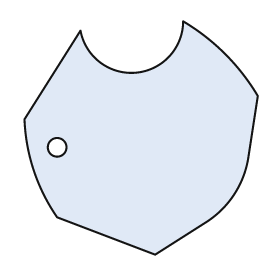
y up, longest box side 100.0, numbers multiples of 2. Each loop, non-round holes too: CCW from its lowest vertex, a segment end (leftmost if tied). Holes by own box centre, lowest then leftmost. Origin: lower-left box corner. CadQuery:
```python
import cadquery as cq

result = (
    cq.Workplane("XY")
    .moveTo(56.0, 0.0)
    .lineTo(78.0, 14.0)
    .threePointArc((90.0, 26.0), (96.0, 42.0))
    .lineTo(100.0, 68.0)
    .threePointArc((86.0, 86.0), (68.0, 100.0))
    .threePointArc((48.0, 78.0), (24.0, 96.0))
    .lineTo(0.0, 58.0)
    .threePointArc((4.0, 36.0), (14.0, 16.0))
    .close()
    .moveTo(14.0, 46.0)
    .circle(4.0)
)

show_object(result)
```